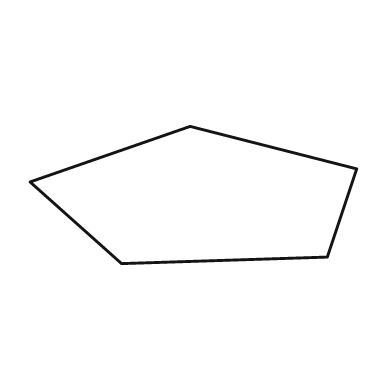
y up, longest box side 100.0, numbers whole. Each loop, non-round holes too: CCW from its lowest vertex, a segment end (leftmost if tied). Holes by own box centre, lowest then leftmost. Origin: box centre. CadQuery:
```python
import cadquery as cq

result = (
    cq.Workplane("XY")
    .moveTo(-22.0, -21.0)
    .lineTo(41.0, -19.0)
    .lineTo(50.0, 8.0)
    .lineTo(-1.0, 21.0)
    .lineTo(-50.0, 4.0)
    .close()
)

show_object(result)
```